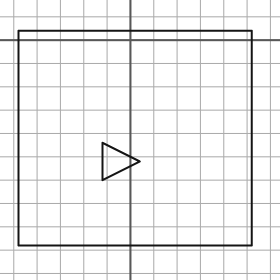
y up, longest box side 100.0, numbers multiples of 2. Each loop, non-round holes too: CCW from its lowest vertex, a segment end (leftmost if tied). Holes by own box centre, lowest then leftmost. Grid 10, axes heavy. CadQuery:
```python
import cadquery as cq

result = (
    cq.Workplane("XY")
    .moveTo(-48.0, -88.0)
    .lineTo(52.0, -88.0)
    .lineTo(52.0, 4.0)
    .lineTo(-48.0, 4.0)
    .close()
    .moveTo(-12.0, -60.0)
    .lineTo(4.0, -52.0)
    .lineTo(-12.0, -44.0)
    .close()
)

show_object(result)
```